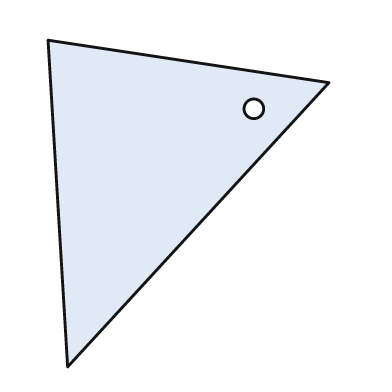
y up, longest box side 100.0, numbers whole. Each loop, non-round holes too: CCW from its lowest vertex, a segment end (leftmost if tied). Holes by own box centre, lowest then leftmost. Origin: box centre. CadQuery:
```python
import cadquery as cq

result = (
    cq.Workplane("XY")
    .moveTo(-37.0, -50.0)
    .lineTo(43.0, 37.0)
    .lineTo(-43.0, 50.0)
    .close()
    .moveTo(20.0, 29.0)
    .circle(3.0)
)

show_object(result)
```